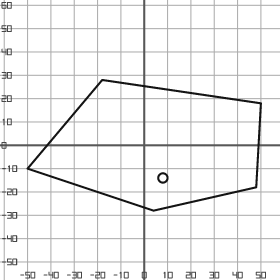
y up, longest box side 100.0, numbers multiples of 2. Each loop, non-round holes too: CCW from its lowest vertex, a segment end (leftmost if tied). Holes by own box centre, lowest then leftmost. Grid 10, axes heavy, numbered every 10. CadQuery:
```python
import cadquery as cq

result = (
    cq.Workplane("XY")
    .moveTo(4.0, -28.0)
    .lineTo(48.0, -18.0)
    .lineTo(50.0, 18.0)
    .lineTo(-18.0, 28.0)
    .lineTo(-50.0, -10.0)
    .close()
    .moveTo(8.0, -14.0)
    .circle(2.0)
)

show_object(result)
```